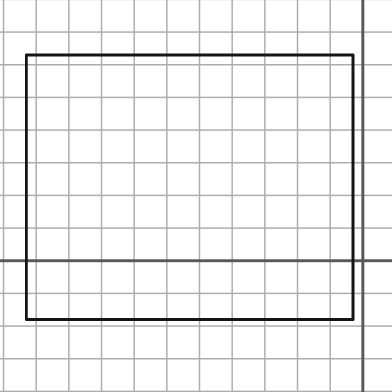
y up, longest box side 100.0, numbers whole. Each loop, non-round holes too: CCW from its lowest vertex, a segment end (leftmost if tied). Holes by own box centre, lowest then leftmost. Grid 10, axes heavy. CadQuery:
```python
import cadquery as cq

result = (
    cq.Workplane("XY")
    .moveTo(-103.0, -18.0)
    .lineTo(-3.0, -18.0)
    .lineTo(-3.0, 63.0)
    .lineTo(-103.0, 63.0)
    .close()
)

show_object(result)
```